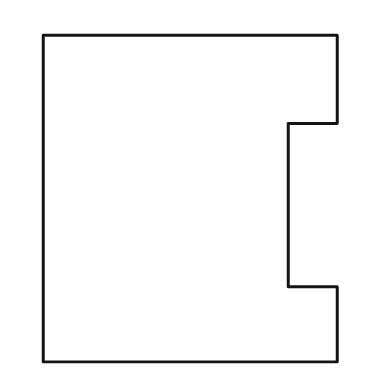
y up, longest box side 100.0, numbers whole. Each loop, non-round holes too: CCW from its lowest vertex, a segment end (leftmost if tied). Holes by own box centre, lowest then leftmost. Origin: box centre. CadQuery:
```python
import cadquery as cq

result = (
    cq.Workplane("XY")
    .moveTo(-45.0, -50.0)
    .lineTo(45.0, -50.0)
    .lineTo(45.0, -27.0)
    .lineTo(30.0, -27.0)
    .lineTo(30.0, 23.0)
    .lineTo(45.0, 23.0)
    .lineTo(45.0, 50.0)
    .lineTo(-45.0, 50.0)
    .close()
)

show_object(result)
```